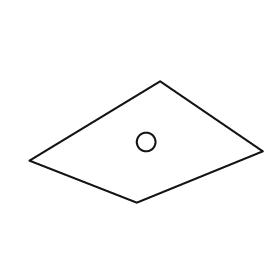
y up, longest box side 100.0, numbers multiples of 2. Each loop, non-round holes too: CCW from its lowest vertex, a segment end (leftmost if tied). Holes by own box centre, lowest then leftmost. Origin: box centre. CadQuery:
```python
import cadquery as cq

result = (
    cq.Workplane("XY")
    .moveTo(-4.0, -26.0)
    .lineTo(50.0, -4.0)
    .lineTo(6.0, 26.0)
    .lineTo(-50.0, -8.0)
    .close()
    .moveTo(0.0, 0.0)
    .circle(4.0)
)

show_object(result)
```